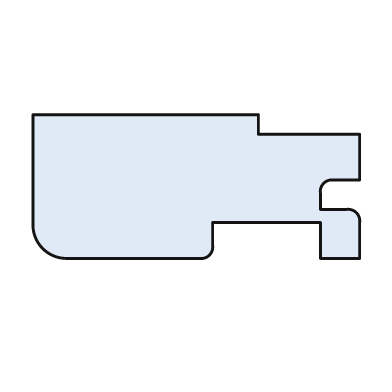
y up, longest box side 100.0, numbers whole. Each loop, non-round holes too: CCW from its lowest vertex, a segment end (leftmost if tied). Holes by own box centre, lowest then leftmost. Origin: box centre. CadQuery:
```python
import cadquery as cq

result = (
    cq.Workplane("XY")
    .moveTo(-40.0, -22.0)
    .lineTo(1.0, -22.0)
    .threePointArc((4.0, -21.0), (5.0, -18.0))
    .lineTo(5.0, -11.0)
    .lineTo(38.0, -11.0)
    .lineTo(38.0, -22.0)
    .lineTo(50.0, -22.0)
    .lineTo(50.0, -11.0)
    .threePointArc((49.0, -8.0), (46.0, -7.0))
    .lineTo(38.0, -7.0)
    .lineTo(38.0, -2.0)
    .threePointArc((39.0, 1.0), (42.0, 2.0))
    .lineTo(50.0, 2.0)
    .lineTo(50.0, 16.0)
    .lineTo(19.0, 16.0)
    .lineTo(19.0, 22.0)
    .lineTo(-50.0, 22.0)
    .lineTo(-50.0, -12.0)
    .threePointArc((-47.0, -19.0), (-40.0, -22.0))
    .close()
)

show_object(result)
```